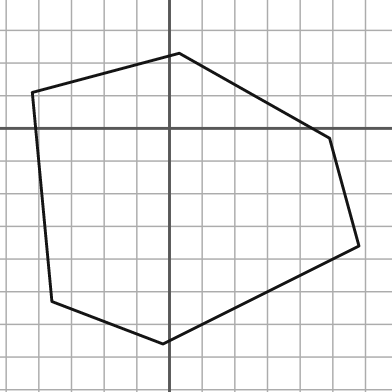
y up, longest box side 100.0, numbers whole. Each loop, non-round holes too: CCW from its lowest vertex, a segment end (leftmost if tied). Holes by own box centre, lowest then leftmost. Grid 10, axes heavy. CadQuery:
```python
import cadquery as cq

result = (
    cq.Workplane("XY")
    .moveTo(-2.0, -66.0)
    .lineTo(58.0, -36.0)
    .lineTo(49.0, -3.0)
    .lineTo(3.0, 23.0)
    .lineTo(-42.0, 11.0)
    .lineTo(-36.0, -53.0)
    .close()
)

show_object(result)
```